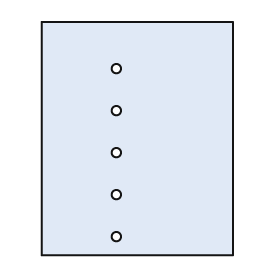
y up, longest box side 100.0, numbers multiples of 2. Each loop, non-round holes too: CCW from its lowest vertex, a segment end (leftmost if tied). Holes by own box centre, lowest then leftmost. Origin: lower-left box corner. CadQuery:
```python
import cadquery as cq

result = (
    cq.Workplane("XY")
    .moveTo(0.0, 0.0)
    .lineTo(82.0, 0.0)
    .lineTo(82.0, 100.0)
    .lineTo(0.0, 100.0)
    .close()
    .moveTo(32.0, 8.0)
    .circle(2.0)
    .moveTo(32.0, 26.0)
    .circle(2.0)
    .moveTo(32.0, 44.0)
    .circle(2.0)
    .moveTo(32.0, 62.0)
    .circle(2.0)
    .moveTo(32.0, 80.0)
    .circle(2.0)
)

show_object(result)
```